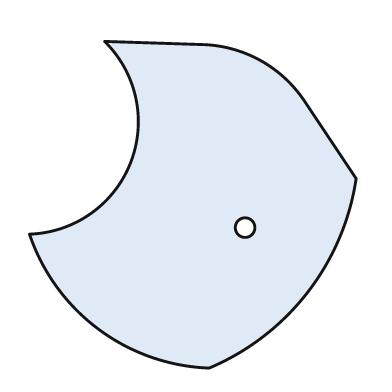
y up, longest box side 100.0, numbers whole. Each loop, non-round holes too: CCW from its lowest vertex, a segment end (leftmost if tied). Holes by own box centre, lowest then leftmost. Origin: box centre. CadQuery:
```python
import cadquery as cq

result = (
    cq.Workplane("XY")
    .moveTo(5.0, -50.0)
    .threePointArc((35.0, -27.0), (50.0, 8.0))
    .lineTo(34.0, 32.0)
    .threePointArc((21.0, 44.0), (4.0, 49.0))
    .lineTo(-27.0, 50.0)
    .threePointArc((-19.0, 13.0), (-50.0, -9.0))
    .threePointArc((-29.0, -38.0), (5.0, -50.0))
    .close()
    .moveTo(16.0, -7.0)
    .circle(3.0)
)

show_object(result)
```